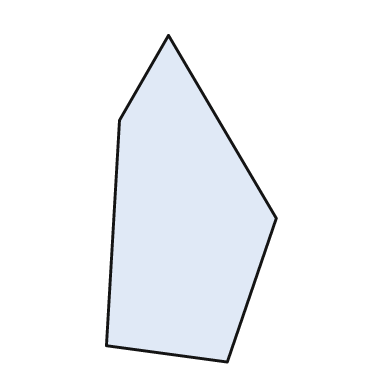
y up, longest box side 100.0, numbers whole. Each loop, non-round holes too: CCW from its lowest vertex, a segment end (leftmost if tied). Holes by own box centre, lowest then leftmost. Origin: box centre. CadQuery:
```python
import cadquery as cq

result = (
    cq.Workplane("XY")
    .moveTo(11.0, -50.0)
    .lineTo(26.0, -6.0)
    .lineTo(-7.0, 50.0)
    .lineTo(-22.0, 24.0)
    .lineTo(-26.0, -45.0)
    .close()
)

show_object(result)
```